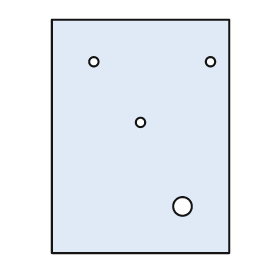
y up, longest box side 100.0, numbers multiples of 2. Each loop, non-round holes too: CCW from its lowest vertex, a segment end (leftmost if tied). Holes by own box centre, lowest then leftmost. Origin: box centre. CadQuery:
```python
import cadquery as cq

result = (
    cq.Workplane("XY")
    .moveTo(-38.0, -50.0)
    .lineTo(38.0, -50.0)
    .lineTo(38.0, 50.0)
    .lineTo(-38.0, 50.0)
    .close()
    .moveTo(18.0, -30.0)
    .circle(4.0)
    .moveTo(0.0, 6.0)
    .circle(2.0)
    .moveTo(-20.0, 32.0)
    .circle(2.0)
    .moveTo(30.0, 32.0)
    .circle(2.0)
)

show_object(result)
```